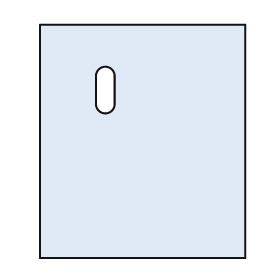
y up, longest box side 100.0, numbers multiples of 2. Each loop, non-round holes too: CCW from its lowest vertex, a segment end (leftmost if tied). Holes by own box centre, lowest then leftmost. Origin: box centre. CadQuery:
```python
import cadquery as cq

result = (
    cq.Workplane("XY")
    .moveTo(-44.0, -50.0)
    .lineTo(44.0, -50.0)
    .lineTo(44.0, 50.0)
    .lineTo(-44.0, 50.0)
    .close()
    .moveTo(-20.0, 16.0)
    .threePointArc((-16.0, 12.0), (-12.0, 16.0))
    .lineTo(-12.0, 28.0)
    .threePointArc((-16.0, 32.0), (-20.0, 28.0))
    .close()
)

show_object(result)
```